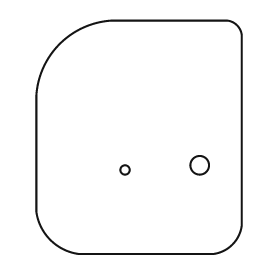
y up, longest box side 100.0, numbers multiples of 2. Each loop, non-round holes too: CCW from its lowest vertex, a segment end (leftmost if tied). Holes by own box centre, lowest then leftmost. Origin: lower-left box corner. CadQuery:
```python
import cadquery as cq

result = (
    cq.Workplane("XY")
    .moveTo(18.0, 0.0)
    .lineTo(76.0, 0.0)
    .threePointArc((84.0, 4.0), (88.0, 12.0))
    .lineTo(88.0, 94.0)
    .threePointArc((86.0, 98.0), (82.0, 100.0))
    .lineTo(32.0, 100.0)
    .threePointArc((10.0, 90.0), (0.0, 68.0))
    .lineTo(0.0, 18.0)
    .threePointArc((6.0, 6.0), (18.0, 0.0))
    .close()
    .moveTo(38.0, 36.0)
    .circle(2.0)
    .moveTo(70.0, 38.0)
    .circle(4.0)
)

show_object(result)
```